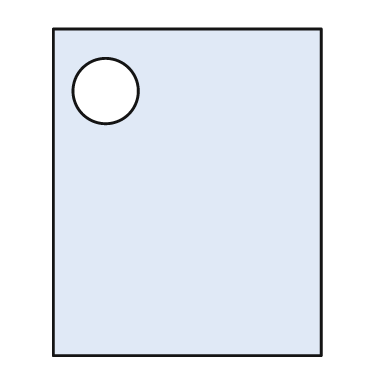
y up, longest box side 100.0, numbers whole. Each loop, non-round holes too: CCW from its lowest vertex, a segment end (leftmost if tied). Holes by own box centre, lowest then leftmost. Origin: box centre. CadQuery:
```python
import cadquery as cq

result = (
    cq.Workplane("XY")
    .moveTo(-41.0, -50.0)
    .lineTo(41.0, -50.0)
    .lineTo(41.0, 50.0)
    .lineTo(-41.0, 50.0)
    .close()
    .moveTo(-25.0, 31.0)
    .circle(10.0)
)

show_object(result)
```